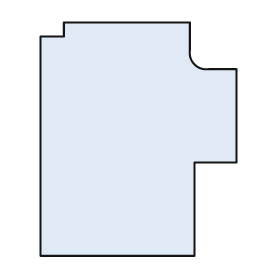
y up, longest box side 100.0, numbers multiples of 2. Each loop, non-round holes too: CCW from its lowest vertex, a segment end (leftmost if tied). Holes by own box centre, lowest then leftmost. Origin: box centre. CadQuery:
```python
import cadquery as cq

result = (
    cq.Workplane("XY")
    .moveTo(-42.0, -50.0)
    .lineTo(24.0, -50.0)
    .lineTo(24.0, -10.0)
    .lineTo(42.0, -10.0)
    .lineTo(42.0, 30.0)
    .lineTo(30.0, 30.0)
    .threePointArc((24.0, 32.0), (22.0, 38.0))
    .lineTo(22.0, 50.0)
    .lineTo(-32.0, 50.0)
    .lineTo(-32.0, 44.0)
    .lineTo(-42.0, 44.0)
    .close()
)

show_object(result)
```